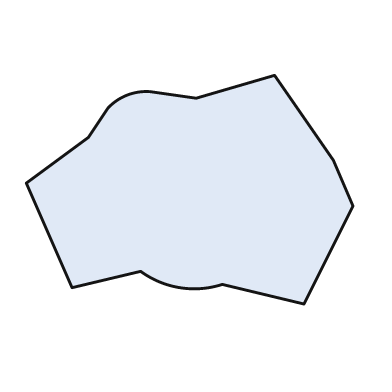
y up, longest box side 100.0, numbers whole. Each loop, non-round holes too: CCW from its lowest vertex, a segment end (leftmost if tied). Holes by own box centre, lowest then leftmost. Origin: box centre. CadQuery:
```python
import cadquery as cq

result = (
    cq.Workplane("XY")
    .moveTo(35.0, -35.0)
    .lineTo(50.0, -5.0)
    .lineTo(44.0, 9.0)
    .lineTo(26.0, 35.0)
    .lineTo(2.0, 28.0)
    .lineTo(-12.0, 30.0)
    .threePointArc((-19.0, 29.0), (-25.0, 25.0))
    .lineTo(-31.0, 16.0)
    .lineTo(-50.0, 2.0)
    .lineTo(-36.0, -30.0)
    .lineTo(-15.0, -25.0)
    .threePointArc((-3.0, -30.0), (10.0, -29.0))
    .close()
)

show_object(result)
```